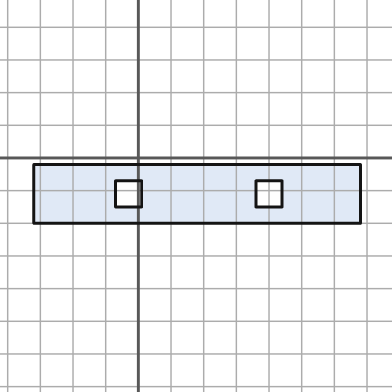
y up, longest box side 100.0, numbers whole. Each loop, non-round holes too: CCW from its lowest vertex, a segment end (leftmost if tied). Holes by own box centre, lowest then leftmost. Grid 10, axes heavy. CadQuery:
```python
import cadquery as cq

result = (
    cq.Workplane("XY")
    .moveTo(-32.0, -20.0)
    .lineTo(68.0, -20.0)
    .lineTo(68.0, -2.0)
    .lineTo(-32.0, -2.0)
    .close()
    .moveTo(-7.0, -15.0)
    .lineTo(1.0, -15.0)
    .lineTo(1.0, -7.0)
    .lineTo(-7.0, -7.0)
    .close()
    .moveTo(36.0, -15.0)
    .lineTo(44.0, -15.0)
    .lineTo(44.0, -7.0)
    .lineTo(36.0, -7.0)
    .close()
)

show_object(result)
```